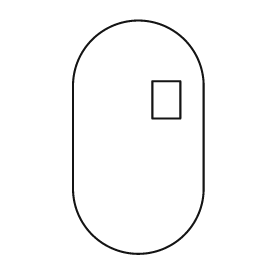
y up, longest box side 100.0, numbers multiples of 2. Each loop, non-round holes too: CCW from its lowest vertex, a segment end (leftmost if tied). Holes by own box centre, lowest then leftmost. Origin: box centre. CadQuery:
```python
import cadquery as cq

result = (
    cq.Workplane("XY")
    .moveTo(-28.0, -22.0)
    .threePointArc((0.0, -50.0), (28.0, -22.0))
    .lineTo(28.0, 22.0)
    .threePointArc((0.0, 50.0), (-28.0, 22.0))
    .close()
    .moveTo(6.0, 8.0)
    .lineTo(18.0, 8.0)
    .lineTo(18.0, 24.0)
    .lineTo(6.0, 24.0)
    .close()
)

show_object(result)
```